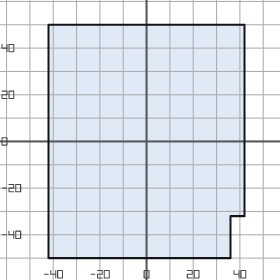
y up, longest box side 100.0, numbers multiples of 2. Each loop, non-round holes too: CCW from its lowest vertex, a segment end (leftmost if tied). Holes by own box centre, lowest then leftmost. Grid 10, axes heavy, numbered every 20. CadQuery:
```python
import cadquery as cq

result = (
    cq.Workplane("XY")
    .moveTo(-42.0, -50.0)
    .lineTo(36.0, -50.0)
    .lineTo(36.0, -32.0)
    .lineTo(42.0, -32.0)
    .lineTo(42.0, 50.0)
    .lineTo(-42.0, 50.0)
    .close()
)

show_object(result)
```